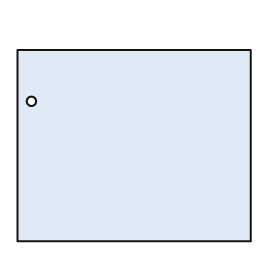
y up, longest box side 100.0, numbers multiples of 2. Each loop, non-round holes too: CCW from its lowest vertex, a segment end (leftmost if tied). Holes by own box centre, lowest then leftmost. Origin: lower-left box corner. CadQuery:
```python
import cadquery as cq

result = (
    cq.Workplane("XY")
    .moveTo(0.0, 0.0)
    .lineTo(100.0, 0.0)
    .lineTo(100.0, 82.0)
    .lineTo(0.0, 82.0)
    .close()
    .moveTo(6.0, 60.0)
    .circle(2.0)
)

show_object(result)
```